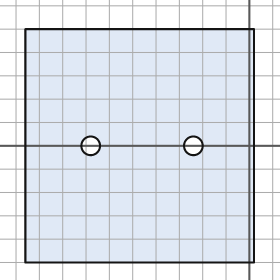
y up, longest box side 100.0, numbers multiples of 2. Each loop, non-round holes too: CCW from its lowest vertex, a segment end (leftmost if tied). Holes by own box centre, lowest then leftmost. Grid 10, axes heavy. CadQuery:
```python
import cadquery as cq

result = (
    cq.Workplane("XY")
    .moveTo(-96.0, -50.0)
    .lineTo(2.0, -50.0)
    .lineTo(2.0, 50.0)
    .lineTo(-96.0, 50.0)
    .close()
    .moveTo(-68.0, 0.0)
    .circle(4.0)
    .moveTo(-24.0, 0.0)
    .circle(4.0)
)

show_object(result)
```